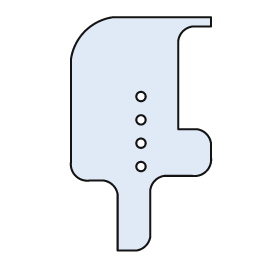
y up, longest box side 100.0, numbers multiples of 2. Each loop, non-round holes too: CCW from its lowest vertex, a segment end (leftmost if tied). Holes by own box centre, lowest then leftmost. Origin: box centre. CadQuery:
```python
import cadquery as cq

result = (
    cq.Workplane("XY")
    .moveTo(-10.0, -50.0)
    .lineTo(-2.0, -50.0)
    .threePointArc((2.0, -48.0), (4.0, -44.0))
    .lineTo(4.0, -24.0)
    .threePointArc((6.0, -20.0), (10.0, -18.0))
    .lineTo(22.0, -18.0)
    .threePointArc((28.0, -16.0), (30.0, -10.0))
    .lineTo(30.0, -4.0)
    .threePointArc((28.0, 0.0), (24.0, 2.0))
    .lineTo(16.0, 2.0)
    .lineTo(16.0, 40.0)
    .threePointArc((18.0, 44.0), (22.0, 46.0))
    .lineTo(30.0, 46.0)
    .lineTo(30.0, 50.0)
    .lineTo(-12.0, 50.0)
    .threePointArc((-24.0, 44.0), (-30.0, 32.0))
    .lineTo(-30.0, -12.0)
    .threePointArc((-28.0, -18.0), (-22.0, -20.0))
    .lineTo(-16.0, -20.0)
    .threePointArc((-12.0, -22.0), (-10.0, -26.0))
    .close()
    .moveTo(0.0, -14.0)
    .circle(2.0)
    .moveTo(0.0, -4.0)
    .circle(2.0)
    .moveTo(0.0, 6.0)
    .circle(2.0)
    .moveTo(0.0, 16.0)
    .circle(2.0)
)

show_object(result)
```